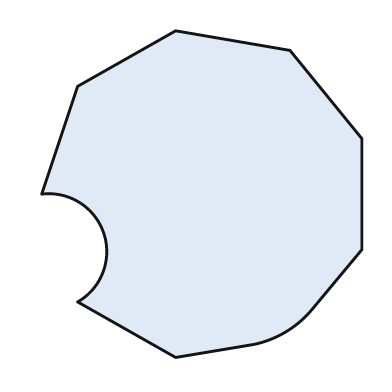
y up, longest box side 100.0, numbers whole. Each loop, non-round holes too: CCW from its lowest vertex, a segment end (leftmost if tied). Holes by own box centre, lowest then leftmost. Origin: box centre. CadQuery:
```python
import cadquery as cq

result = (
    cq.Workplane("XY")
    .moveTo(-8.0, -50.0)
    .lineTo(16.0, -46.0)
    .threePointArc((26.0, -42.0), (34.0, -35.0))
    .lineTo(49.0, -17.0)
    .lineTo(49.0, 17.0)
    .lineTo(27.0, 44.0)
    .lineTo(-8.0, 50.0)
    .lineTo(-38.0, 33.0)
    .lineTo(-49.0, 0.0)
    .threePointArc((-30.0, -12.0), (-38.0, -33.0))
    .close()
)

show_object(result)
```